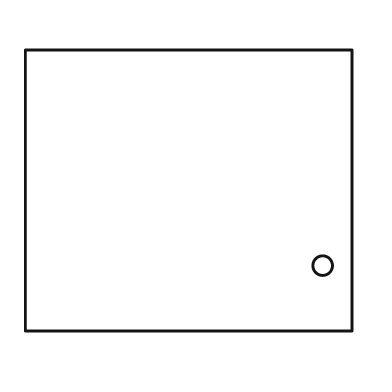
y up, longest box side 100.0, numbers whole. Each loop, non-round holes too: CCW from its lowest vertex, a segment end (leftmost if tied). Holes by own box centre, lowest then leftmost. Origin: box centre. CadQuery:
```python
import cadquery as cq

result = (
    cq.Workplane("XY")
    .moveTo(-50.0, -43.0)
    .lineTo(50.0, -43.0)
    .lineTo(50.0, 43.0)
    .lineTo(-50.0, 43.0)
    .close()
    .moveTo(41.0, -23.0)
    .circle(3.0)
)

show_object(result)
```